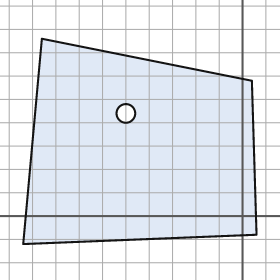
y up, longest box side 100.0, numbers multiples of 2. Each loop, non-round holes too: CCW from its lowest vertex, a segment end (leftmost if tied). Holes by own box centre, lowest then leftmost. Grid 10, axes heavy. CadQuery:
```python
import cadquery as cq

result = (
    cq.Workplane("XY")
    .moveTo(-94.0, -12.0)
    .lineTo(6.0, -8.0)
    .lineTo(4.0, 58.0)
    .lineTo(-86.0, 76.0)
    .close()
    .moveTo(-50.0, 44.0)
    .circle(4.0)
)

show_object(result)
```